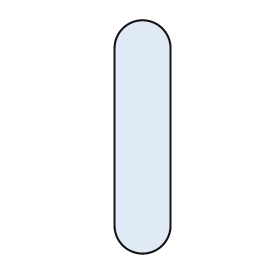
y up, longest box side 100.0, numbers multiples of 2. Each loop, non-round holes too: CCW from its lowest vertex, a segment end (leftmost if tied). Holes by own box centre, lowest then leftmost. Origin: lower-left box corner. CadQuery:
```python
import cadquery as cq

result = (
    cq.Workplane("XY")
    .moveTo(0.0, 12.0)
    .threePointArc((12.0, 0.0), (24.0, 12.0))
    .lineTo(24.0, 88.0)
    .threePointArc((12.0, 100.0), (0.0, 88.0))
    .close()
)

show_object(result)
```